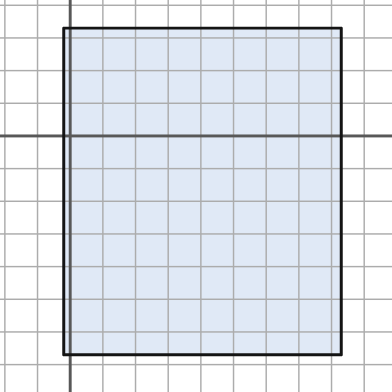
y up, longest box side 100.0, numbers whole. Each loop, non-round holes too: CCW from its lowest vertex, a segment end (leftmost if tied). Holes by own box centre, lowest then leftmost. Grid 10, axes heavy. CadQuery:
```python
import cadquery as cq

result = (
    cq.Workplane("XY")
    .moveTo(-2.0, -67.0)
    .lineTo(83.0, -67.0)
    .lineTo(83.0, 33.0)
    .lineTo(-2.0, 33.0)
    .close()
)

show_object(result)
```